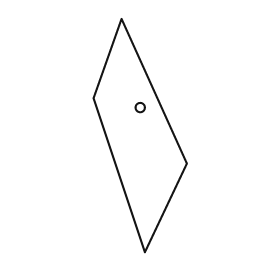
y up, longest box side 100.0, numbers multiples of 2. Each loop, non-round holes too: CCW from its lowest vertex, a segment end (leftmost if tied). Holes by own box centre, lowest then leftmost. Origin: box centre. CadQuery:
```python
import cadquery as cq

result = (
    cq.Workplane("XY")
    .moveTo(2.0, -50.0)
    .lineTo(20.0, -12.0)
    .lineTo(-8.0, 50.0)
    .lineTo(-20.0, 16.0)
    .close()
    .moveTo(0.0, 12.0)
    .circle(2.0)
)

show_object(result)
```